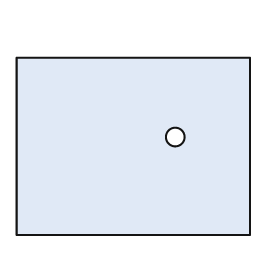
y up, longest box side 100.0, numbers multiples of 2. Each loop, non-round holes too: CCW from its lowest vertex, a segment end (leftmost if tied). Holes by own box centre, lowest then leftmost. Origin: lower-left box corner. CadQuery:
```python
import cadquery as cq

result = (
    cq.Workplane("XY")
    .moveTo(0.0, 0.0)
    .lineTo(100.0, 0.0)
    .lineTo(100.0, 76.0)
    .lineTo(0.0, 76.0)
    .close()
    .moveTo(68.0, 42.0)
    .circle(4.0)
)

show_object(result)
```